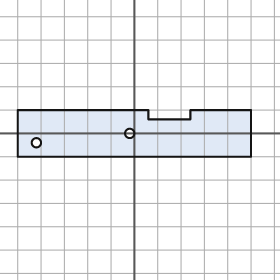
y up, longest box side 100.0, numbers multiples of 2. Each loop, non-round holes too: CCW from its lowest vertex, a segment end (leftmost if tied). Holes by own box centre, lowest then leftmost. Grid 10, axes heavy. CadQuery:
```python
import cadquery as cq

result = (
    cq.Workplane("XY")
    .moveTo(-50.0, -10.0)
    .lineTo(50.0, -10.0)
    .lineTo(50.0, 10.0)
    .lineTo(24.0, 10.0)
    .lineTo(24.0, 6.0)
    .lineTo(6.0, 6.0)
    .lineTo(6.0, 10.0)
    .lineTo(-50.0, 10.0)
    .close()
    .moveTo(-42.0, -4.0)
    .circle(2.0)
    .moveTo(-2.0, 0.0)
    .circle(2.0)
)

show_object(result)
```